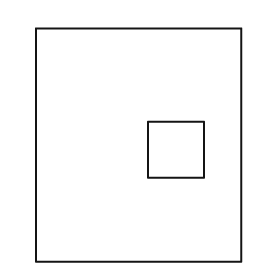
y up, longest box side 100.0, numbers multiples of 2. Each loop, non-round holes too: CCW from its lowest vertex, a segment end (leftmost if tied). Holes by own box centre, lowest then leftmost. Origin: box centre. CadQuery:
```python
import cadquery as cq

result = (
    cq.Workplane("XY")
    .moveTo(-44.0, -50.0)
    .lineTo(44.0, -50.0)
    .lineTo(44.0, 50.0)
    .lineTo(-44.0, 50.0)
    .close()
    .moveTo(4.0, -14.0)
    .lineTo(28.0, -14.0)
    .lineTo(28.0, 10.0)
    .lineTo(4.0, 10.0)
    .close()
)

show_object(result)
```